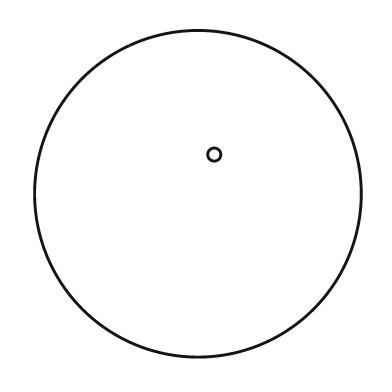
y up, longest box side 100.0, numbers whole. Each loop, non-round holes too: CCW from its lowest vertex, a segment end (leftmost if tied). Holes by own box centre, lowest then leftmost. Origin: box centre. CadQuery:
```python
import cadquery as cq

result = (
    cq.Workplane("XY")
    .moveTo(0.0, 0.0)
    .circle(50.0)
    .moveTo(5.0, 12.0)
    .circle(2.0)
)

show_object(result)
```